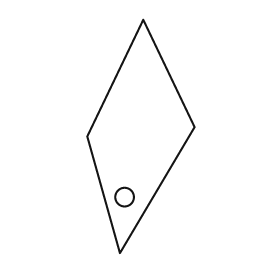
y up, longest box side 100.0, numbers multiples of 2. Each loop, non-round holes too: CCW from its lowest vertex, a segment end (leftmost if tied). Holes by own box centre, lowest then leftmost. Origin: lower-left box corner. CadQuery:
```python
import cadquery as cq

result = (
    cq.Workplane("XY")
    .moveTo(14.0, 0.0)
    .lineTo(46.0, 54.0)
    .lineTo(24.0, 100.0)
    .lineTo(0.0, 50.0)
    .close()
    .moveTo(16.0, 24.0)
    .circle(4.0)
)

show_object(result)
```